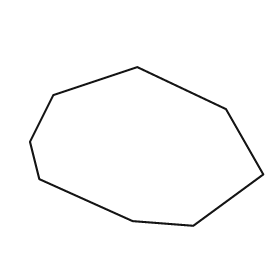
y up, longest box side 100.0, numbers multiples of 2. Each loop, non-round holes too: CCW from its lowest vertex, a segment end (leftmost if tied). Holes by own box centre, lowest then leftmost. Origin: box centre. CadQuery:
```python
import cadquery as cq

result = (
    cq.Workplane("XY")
    .moveTo(20.0, -34.0)
    .lineTo(50.0, -12.0)
    .lineTo(34.0, 16.0)
    .lineTo(-4.0, 34.0)
    .lineTo(-40.0, 22.0)
    .lineTo(-50.0, 2.0)
    .lineTo(-46.0, -14.0)
    .lineTo(-6.0, -32.0)
    .close()
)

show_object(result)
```